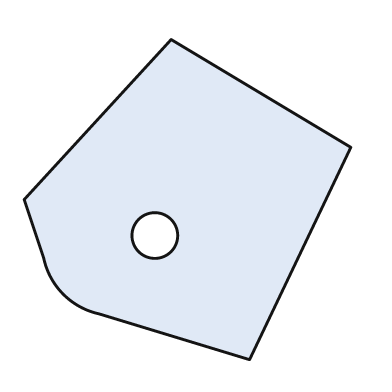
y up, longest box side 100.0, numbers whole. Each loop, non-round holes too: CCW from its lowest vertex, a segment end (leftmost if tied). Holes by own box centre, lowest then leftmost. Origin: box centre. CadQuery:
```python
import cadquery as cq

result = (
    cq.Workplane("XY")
    .moveTo(19.0, -49.0)
    .lineTo(50.0, 16.0)
    .lineTo(-5.0, 49.0)
    .lineTo(-50.0, 0.0)
    .lineTo(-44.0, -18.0)
    .threePointArc((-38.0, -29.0), (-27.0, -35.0))
    .close()
    .moveTo(-10.0, -11.0)
    .circle(7.0)
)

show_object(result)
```